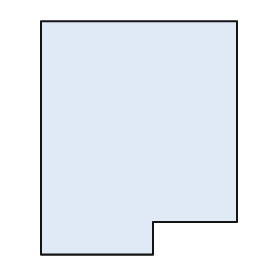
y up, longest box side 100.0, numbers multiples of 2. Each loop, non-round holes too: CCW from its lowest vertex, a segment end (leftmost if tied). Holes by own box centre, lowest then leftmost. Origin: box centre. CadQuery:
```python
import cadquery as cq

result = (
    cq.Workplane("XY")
    .moveTo(-42.0, -50.0)
    .lineTo(6.0, -50.0)
    .lineTo(6.0, -36.0)
    .lineTo(42.0, -36.0)
    .lineTo(42.0, 50.0)
    .lineTo(-42.0, 50.0)
    .close()
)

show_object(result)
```